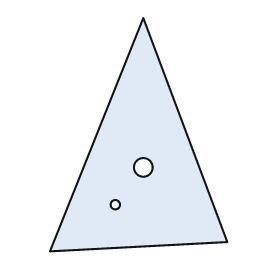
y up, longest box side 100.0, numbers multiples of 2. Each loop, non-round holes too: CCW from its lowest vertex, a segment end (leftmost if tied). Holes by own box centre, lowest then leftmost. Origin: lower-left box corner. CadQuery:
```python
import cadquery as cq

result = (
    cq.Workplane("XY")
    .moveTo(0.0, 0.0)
    .lineTo(76.0, 4.0)
    .lineTo(40.0, 100.0)
    .close()
    .moveTo(28.0, 20.0)
    .circle(2.0)
    .moveTo(40.0, 36.0)
    .circle(4.0)
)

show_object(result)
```